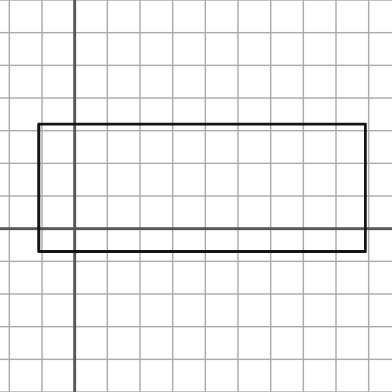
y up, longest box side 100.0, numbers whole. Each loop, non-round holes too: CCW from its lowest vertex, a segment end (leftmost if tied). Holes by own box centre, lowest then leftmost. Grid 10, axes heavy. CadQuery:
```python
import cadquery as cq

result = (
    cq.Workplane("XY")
    .moveTo(-11.0, -7.0)
    .lineTo(89.0, -7.0)
    .lineTo(89.0, 32.0)
    .lineTo(-11.0, 32.0)
    .close()
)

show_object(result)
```